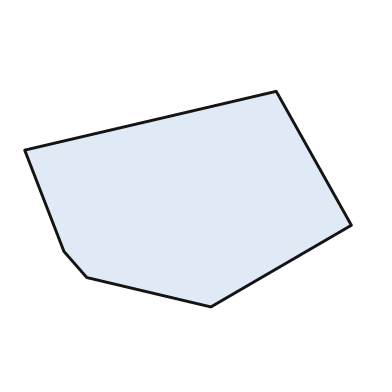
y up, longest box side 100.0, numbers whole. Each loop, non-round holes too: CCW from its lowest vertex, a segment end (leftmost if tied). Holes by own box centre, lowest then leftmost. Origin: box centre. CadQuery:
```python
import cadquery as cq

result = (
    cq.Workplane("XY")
    .moveTo(7.0, -33.0)
    .lineTo(50.0, -8.0)
    .lineTo(27.0, 33.0)
    .lineTo(-50.0, 15.0)
    .lineTo(-38.0, -16.0)
    .lineTo(-31.0, -24.0)
    .close()
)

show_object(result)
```